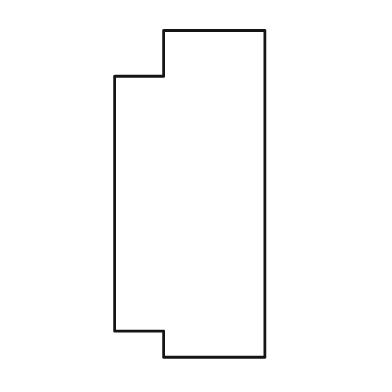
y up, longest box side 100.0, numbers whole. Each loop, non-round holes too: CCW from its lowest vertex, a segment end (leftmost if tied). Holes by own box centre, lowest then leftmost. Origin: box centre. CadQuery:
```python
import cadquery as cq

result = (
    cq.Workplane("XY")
    .moveTo(-8.0, -50.0)
    .lineTo(23.0, -50.0)
    .lineTo(23.0, 50.0)
    .lineTo(-8.0, 50.0)
    .lineTo(-8.0, 36.0)
    .lineTo(-23.0, 36.0)
    .lineTo(-23.0, -42.0)
    .lineTo(-8.0, -42.0)
    .close()
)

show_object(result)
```